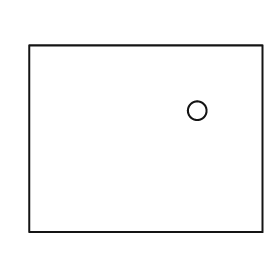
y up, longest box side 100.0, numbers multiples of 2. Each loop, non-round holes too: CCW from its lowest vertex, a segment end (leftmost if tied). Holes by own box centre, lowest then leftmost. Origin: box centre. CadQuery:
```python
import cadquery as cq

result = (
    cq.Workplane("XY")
    .moveTo(-50.0, -40.0)
    .lineTo(50.0, -40.0)
    .lineTo(50.0, 40.0)
    .lineTo(-50.0, 40.0)
    .close()
    .moveTo(22.0, 12.0)
    .circle(4.0)
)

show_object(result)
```